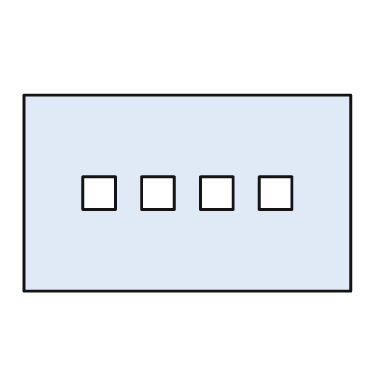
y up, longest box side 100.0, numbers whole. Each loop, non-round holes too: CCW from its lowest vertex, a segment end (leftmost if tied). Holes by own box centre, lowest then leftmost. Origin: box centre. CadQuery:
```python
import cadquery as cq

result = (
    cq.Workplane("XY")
    .moveTo(-50.0, -30.0)
    .lineTo(50.0, -30.0)
    .lineTo(50.0, 30.0)
    .lineTo(-50.0, 30.0)
    .close()
    .moveTo(-32.0, -5.0)
    .lineTo(-22.0, -5.0)
    .lineTo(-22.0, 5.0)
    .lineTo(-32.0, 5.0)
    .close()
    .moveTo(-14.0, -5.0)
    .lineTo(-4.0, -5.0)
    .lineTo(-4.0, 5.0)
    .lineTo(-14.0, 5.0)
    .close()
    .moveTo(4.0, -5.0)
    .lineTo(14.0, -5.0)
    .lineTo(14.0, 5.0)
    .lineTo(4.0, 5.0)
    .close()
    .moveTo(22.0, -5.0)
    .lineTo(32.0, -5.0)
    .lineTo(32.0, 5.0)
    .lineTo(22.0, 5.0)
    .close()
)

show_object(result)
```